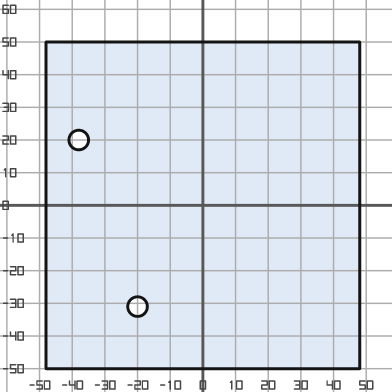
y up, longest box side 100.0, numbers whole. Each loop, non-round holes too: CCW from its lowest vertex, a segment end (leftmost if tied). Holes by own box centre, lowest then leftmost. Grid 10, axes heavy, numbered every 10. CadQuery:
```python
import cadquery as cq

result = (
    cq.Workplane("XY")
    .moveTo(-48.0, -50.0)
    .lineTo(48.0, -50.0)
    .lineTo(48.0, 50.0)
    .lineTo(-48.0, 50.0)
    .close()
    .moveTo(-20.0, -31.0)
    .circle(3.0)
    .moveTo(-38.0, 20.0)
    .circle(3.0)
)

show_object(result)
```